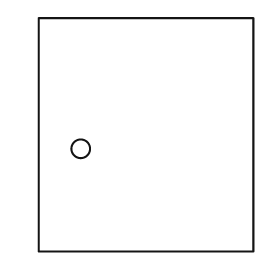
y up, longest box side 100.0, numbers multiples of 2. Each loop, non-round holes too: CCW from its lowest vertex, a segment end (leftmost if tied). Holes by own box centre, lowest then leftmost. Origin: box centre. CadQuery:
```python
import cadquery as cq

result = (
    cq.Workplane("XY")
    .moveTo(-46.0, -50.0)
    .lineTo(46.0, -50.0)
    .lineTo(46.0, 50.0)
    .lineTo(-46.0, 50.0)
    .close()
    .moveTo(-28.0, -6.0)
    .circle(4.0)
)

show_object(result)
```